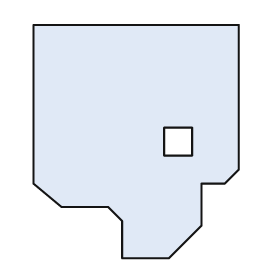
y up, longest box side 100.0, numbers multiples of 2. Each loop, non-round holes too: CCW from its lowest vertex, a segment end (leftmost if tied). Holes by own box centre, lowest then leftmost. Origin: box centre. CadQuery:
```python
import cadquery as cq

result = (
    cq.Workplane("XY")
    .moveTo(-6.0, -50.0)
    .lineTo(14.0, -50.0)
    .lineTo(28.0, -36.0)
    .lineTo(28.0, -18.0)
    .lineTo(38.0, -18.0)
    .lineTo(44.0, -12.0)
    .lineTo(44.0, 50.0)
    .lineTo(-44.0, 50.0)
    .lineTo(-44.0, -18.0)
    .lineTo(-32.0, -28.0)
    .lineTo(-12.0, -28.0)
    .lineTo(-6.0, -34.0)
    .close()
    .moveTo(12.0, -6.0)
    .lineTo(24.0, -6.0)
    .lineTo(24.0, 6.0)
    .lineTo(12.0, 6.0)
    .close()
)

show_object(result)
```